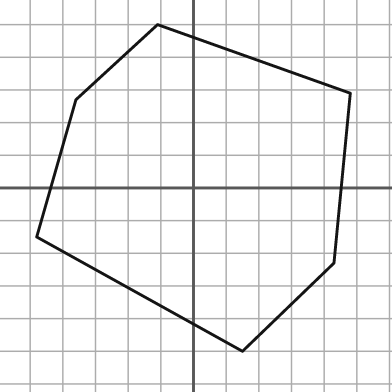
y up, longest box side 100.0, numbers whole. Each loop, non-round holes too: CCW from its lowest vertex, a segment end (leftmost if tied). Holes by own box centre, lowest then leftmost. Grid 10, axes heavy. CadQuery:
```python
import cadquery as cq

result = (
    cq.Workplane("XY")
    .moveTo(15.0, -50.0)
    .lineTo(43.0, -23.0)
    .lineTo(48.0, 29.0)
    .lineTo(-11.0, 50.0)
    .lineTo(-36.0, 27.0)
    .lineTo(-48.0, -15.0)
    .close()
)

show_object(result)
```